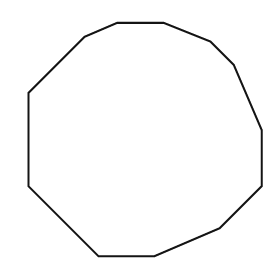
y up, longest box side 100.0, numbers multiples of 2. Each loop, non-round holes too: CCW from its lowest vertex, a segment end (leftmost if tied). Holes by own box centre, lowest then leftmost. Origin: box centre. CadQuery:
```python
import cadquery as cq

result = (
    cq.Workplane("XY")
    .moveTo(-20.0, -50.0)
    .lineTo(4.0, -50.0)
    .lineTo(32.0, -38.0)
    .lineTo(50.0, -20.0)
    .lineTo(50.0, 4.0)
    .lineTo(38.0, 32.0)
    .lineTo(28.0, 42.0)
    .lineTo(8.0, 50.0)
    .lineTo(-12.0, 50.0)
    .lineTo(-26.0, 44.0)
    .lineTo(-50.0, 20.0)
    .lineTo(-50.0, -20.0)
    .close()
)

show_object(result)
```